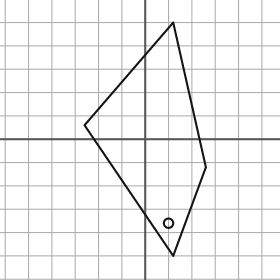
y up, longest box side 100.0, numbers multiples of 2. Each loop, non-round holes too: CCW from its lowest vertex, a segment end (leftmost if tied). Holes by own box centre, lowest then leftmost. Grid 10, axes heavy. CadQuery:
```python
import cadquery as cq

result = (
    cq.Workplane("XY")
    .moveTo(12.0, -50.0)
    .lineTo(26.0, -12.0)
    .lineTo(12.0, 50.0)
    .lineTo(-26.0, 6.0)
    .close()
    .moveTo(10.0, -36.0)
    .circle(2.0)
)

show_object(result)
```